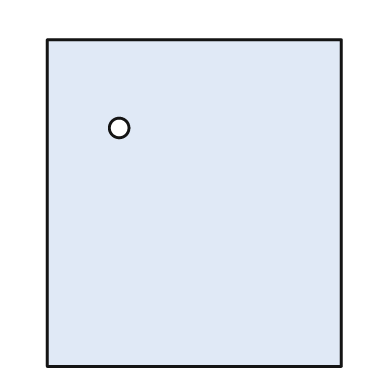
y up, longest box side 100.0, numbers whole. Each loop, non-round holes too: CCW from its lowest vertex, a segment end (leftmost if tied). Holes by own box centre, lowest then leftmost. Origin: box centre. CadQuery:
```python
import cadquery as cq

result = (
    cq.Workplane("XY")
    .moveTo(-45.0, -50.0)
    .lineTo(45.0, -50.0)
    .lineTo(45.0, 50.0)
    .lineTo(-45.0, 50.0)
    .close()
    .moveTo(-23.0, 23.0)
    .circle(3.0)
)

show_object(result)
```